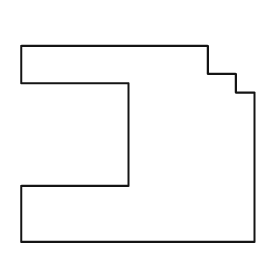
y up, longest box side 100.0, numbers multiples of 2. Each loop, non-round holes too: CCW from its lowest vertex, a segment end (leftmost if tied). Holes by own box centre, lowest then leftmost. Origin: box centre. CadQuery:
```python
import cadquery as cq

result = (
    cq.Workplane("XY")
    .moveTo(-50.0, -42.0)
    .lineTo(50.0, -42.0)
    .lineTo(50.0, 22.0)
    .lineTo(42.0, 22.0)
    .lineTo(42.0, 30.0)
    .lineTo(30.0, 30.0)
    .lineTo(30.0, 42.0)
    .lineTo(-50.0, 42.0)
    .lineTo(-50.0, 26.0)
    .lineTo(-4.0, 26.0)
    .lineTo(-4.0, -18.0)
    .lineTo(-50.0, -18.0)
    .close()
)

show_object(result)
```